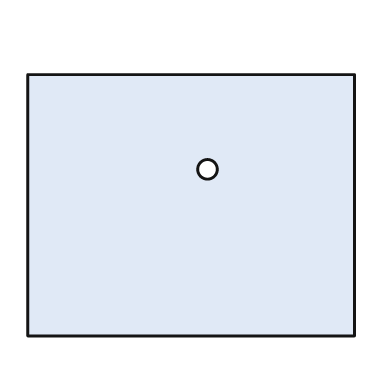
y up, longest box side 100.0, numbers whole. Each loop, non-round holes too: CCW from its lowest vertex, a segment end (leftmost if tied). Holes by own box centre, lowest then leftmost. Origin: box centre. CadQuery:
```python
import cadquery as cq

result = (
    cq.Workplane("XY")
    .moveTo(-50.0, -40.0)
    .lineTo(50.0, -40.0)
    .lineTo(50.0, 40.0)
    .lineTo(-50.0, 40.0)
    .close()
    .moveTo(5.0, 11.0)
    .circle(3.0)
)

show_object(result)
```